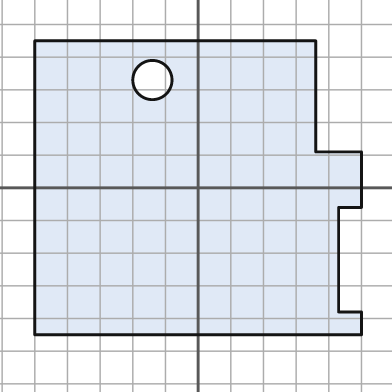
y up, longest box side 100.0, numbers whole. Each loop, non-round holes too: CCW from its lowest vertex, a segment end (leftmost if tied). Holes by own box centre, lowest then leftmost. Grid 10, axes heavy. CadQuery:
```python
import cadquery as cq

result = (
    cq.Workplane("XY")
    .moveTo(-50.0, -45.0)
    .lineTo(50.0, -45.0)
    .lineTo(50.0, -38.0)
    .lineTo(43.0, -38.0)
    .lineTo(43.0, -6.0)
    .lineTo(50.0, -6.0)
    .lineTo(50.0, 11.0)
    .lineTo(36.0, 11.0)
    .lineTo(36.0, 45.0)
    .lineTo(-50.0, 45.0)
    .close()
    .moveTo(-14.0, 33.0)
    .circle(6.0)
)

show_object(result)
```